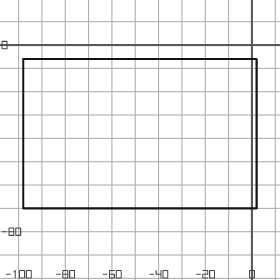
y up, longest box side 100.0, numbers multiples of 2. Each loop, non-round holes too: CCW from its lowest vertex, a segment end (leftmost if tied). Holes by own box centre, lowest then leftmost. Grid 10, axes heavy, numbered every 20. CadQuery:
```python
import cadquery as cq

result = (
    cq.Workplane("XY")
    .moveTo(-98.0, -70.0)
    .lineTo(2.0, -70.0)
    .lineTo(2.0, -6.0)
    .lineTo(-98.0, -6.0)
    .close()
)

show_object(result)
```